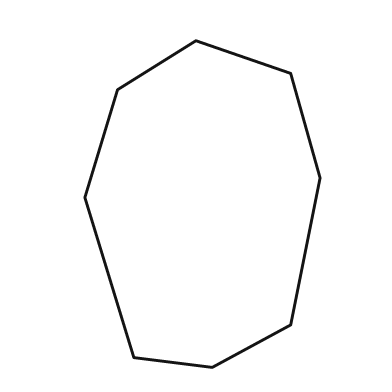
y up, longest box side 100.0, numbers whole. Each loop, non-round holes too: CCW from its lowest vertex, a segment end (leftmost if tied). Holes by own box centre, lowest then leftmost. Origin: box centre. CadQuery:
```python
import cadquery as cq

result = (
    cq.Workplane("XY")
    .moveTo(3.0, -50.0)
    .lineTo(27.0, -37.0)
    .lineTo(36.0, 8.0)
    .lineTo(27.0, 40.0)
    .lineTo(-2.0, 50.0)
    .lineTo(-26.0, 35.0)
    .lineTo(-36.0, 2.0)
    .lineTo(-21.0, -47.0)
    .close()
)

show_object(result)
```